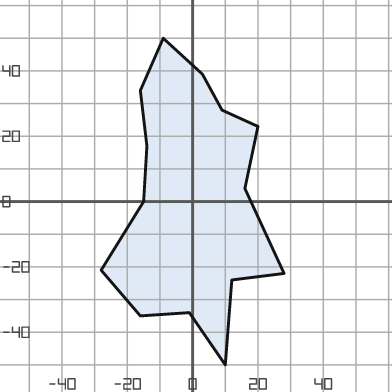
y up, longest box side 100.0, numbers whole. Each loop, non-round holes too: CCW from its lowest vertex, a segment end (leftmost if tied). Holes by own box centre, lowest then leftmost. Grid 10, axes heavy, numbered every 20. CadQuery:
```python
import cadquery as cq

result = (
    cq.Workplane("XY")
    .moveTo(10.0, -50.0)
    .lineTo(12.0, -24.0)
    .lineTo(28.0, -22.0)
    .lineTo(16.0, 4.0)
    .lineTo(20.0, 23.0)
    .lineTo(9.0, 28.0)
    .lineTo(3.0, 39.0)
    .lineTo(-9.0, 50.0)
    .lineTo(-16.0, 34.0)
    .lineTo(-14.0, 17.0)
    .lineTo(-15.0, 0.0)
    .lineTo(-28.0, -21.0)
    .lineTo(-16.0, -35.0)
    .lineTo(-1.0, -34.0)
    .close()
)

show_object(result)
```